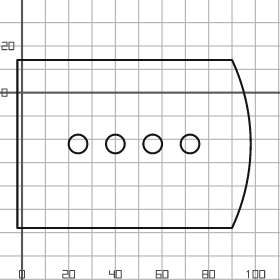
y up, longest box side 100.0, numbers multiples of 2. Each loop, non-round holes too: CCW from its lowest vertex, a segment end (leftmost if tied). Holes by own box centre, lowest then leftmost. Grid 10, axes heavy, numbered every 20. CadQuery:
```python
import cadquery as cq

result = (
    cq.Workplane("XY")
    .moveTo(-2.0, -58.0)
    .lineTo(90.0, -58.0)
    .threePointArc((98.0, -22.0), (90.0, 14.0))
    .lineTo(-2.0, 14.0)
    .close()
    .moveTo(24.0, -22.0)
    .circle(4.0)
    .moveTo(40.0, -22.0)
    .circle(4.0)
    .moveTo(56.0, -22.0)
    .circle(4.0)
    .moveTo(72.0, -22.0)
    .circle(4.0)
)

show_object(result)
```